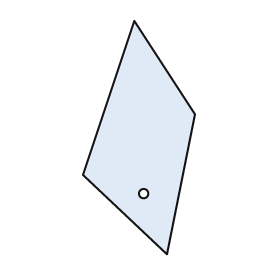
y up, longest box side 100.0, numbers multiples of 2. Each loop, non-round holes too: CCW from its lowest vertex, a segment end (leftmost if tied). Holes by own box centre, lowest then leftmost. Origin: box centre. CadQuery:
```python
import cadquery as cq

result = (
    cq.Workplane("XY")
    .moveTo(12.0, -50.0)
    .lineTo(24.0, 10.0)
    .lineTo(-2.0, 50.0)
    .lineTo(-24.0, -16.0)
    .close()
    .moveTo(2.0, -24.0)
    .circle(2.0)
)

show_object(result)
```